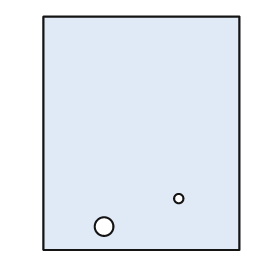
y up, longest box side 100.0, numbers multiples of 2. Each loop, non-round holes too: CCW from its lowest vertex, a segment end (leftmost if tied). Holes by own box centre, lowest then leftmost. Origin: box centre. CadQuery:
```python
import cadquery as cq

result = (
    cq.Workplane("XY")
    .moveTo(-42.0, -50.0)
    .lineTo(42.0, -50.0)
    .lineTo(42.0, 50.0)
    .lineTo(-42.0, 50.0)
    .close()
    .moveTo(-16.0, -40.0)
    .circle(4.0)
    .moveTo(16.0, -28.0)
    .circle(2.0)
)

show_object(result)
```